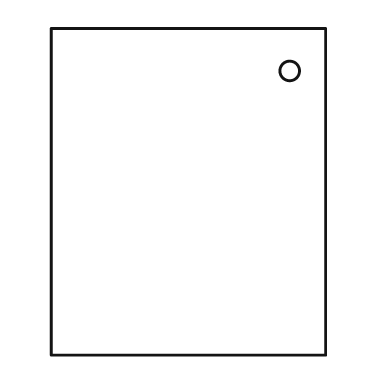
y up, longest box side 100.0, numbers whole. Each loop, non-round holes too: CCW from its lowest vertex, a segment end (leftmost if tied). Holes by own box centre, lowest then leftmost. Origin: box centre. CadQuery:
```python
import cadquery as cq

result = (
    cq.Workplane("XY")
    .moveTo(-42.0, -50.0)
    .lineTo(42.0, -50.0)
    .lineTo(42.0, 50.0)
    .lineTo(-42.0, 50.0)
    .close()
    .moveTo(31.0, 37.0)
    .circle(3.0)
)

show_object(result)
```